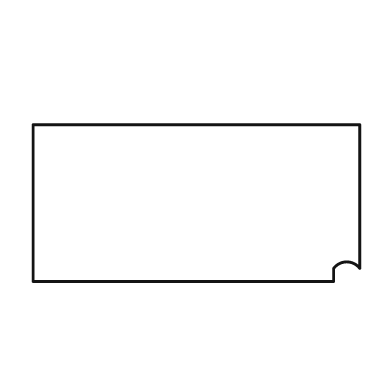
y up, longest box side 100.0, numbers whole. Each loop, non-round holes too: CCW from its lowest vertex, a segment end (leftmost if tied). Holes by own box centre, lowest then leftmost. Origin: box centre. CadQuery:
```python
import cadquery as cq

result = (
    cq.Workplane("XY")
    .moveTo(-50.0, -24.0)
    .lineTo(42.0, -24.0)
    .lineTo(42.0, -20.0)
    .threePointArc((46.0, -18.0), (50.0, -20.0))
    .lineTo(50.0, 24.0)
    .lineTo(-50.0, 24.0)
    .close()
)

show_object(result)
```